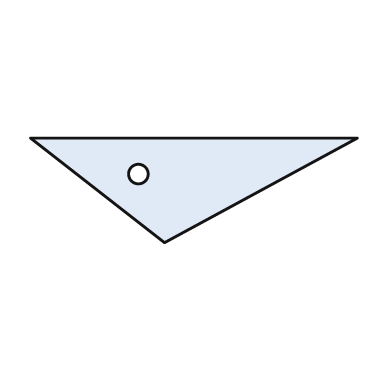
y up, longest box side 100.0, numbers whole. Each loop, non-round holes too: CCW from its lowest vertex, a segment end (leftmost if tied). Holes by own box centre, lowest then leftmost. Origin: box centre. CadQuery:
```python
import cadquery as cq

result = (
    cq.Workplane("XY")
    .moveTo(-9.0, -16.0)
    .lineTo(50.0, 16.0)
    .lineTo(-50.0, 16.0)
    .close()
    .moveTo(-17.0, 5.0)
    .circle(3.0)
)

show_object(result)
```